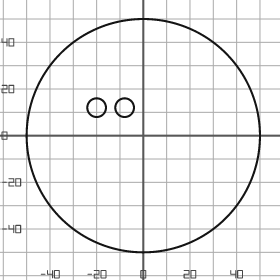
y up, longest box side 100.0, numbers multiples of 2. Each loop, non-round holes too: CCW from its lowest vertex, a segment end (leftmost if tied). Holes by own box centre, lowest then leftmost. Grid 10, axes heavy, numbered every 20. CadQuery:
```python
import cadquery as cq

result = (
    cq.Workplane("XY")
    .moveTo(0.0, 0.0)
    .circle(50.0)
    .moveTo(-20.0, 12.0)
    .circle(4.0)
    .moveTo(-8.0, 12.0)
    .circle(4.0)
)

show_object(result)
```